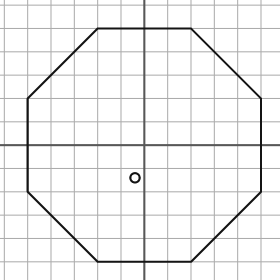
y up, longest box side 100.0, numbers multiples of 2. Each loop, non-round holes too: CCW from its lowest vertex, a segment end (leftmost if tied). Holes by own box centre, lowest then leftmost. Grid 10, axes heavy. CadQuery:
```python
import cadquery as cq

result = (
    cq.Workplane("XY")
    .moveTo(-20.0, -50.0)
    .lineTo(20.0, -50.0)
    .lineTo(50.0, -20.0)
    .lineTo(50.0, 20.0)
    .lineTo(20.0, 50.0)
    .lineTo(-20.0, 50.0)
    .lineTo(-50.0, 20.0)
    .lineTo(-50.0, -20.0)
    .close()
    .moveTo(-4.0, -14.0)
    .circle(2.0)
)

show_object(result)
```